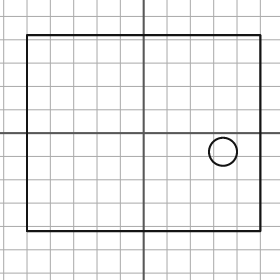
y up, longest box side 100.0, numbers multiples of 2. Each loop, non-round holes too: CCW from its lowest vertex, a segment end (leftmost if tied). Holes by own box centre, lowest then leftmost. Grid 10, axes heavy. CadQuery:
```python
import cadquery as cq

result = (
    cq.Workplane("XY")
    .moveTo(-50.0, -42.0)
    .lineTo(50.0, -42.0)
    .lineTo(50.0, 42.0)
    .lineTo(-50.0, 42.0)
    .close()
    .moveTo(34.0, -8.0)
    .circle(6.0)
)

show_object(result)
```